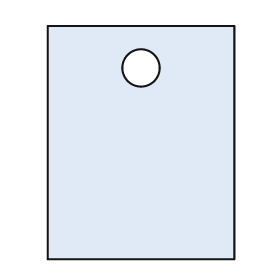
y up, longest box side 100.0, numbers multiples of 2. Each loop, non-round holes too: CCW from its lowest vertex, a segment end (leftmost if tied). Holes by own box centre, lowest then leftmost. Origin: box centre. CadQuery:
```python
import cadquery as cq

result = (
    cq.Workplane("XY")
    .moveTo(-40.0, -50.0)
    .lineTo(40.0, -50.0)
    .lineTo(40.0, 50.0)
    .lineTo(-40.0, 50.0)
    .close()
    .moveTo(0.0, 32.0)
    .circle(8.0)
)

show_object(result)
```